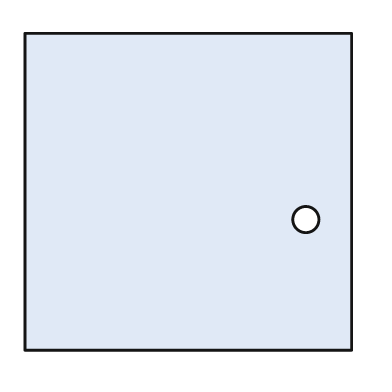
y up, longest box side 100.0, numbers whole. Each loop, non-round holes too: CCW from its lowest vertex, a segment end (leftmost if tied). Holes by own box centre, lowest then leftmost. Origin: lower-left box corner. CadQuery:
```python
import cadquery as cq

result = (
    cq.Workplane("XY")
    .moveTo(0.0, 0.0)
    .lineTo(100.0, 0.0)
    .lineTo(100.0, 97.0)
    .lineTo(0.0, 97.0)
    .close()
    .moveTo(86.0, 40.0)
    .circle(4.0)
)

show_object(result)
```